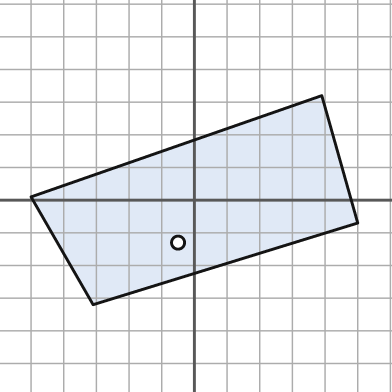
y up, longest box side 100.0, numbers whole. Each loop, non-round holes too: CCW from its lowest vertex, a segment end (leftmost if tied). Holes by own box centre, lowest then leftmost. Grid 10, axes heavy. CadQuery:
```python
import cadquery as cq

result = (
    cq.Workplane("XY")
    .moveTo(-31.0, -32.0)
    .lineTo(50.0, -7.0)
    .lineTo(39.0, 32.0)
    .lineTo(-50.0, 1.0)
    .close()
    .moveTo(-5.0, -13.0)
    .circle(2.0)
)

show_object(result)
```